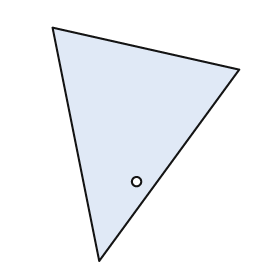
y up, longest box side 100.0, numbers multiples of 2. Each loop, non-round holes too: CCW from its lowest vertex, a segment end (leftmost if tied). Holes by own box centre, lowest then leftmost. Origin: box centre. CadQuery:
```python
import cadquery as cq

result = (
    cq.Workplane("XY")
    .moveTo(-20.0, -50.0)
    .lineTo(40.0, 32.0)
    .lineTo(-40.0, 50.0)
    .close()
    .moveTo(-4.0, -16.0)
    .circle(2.0)
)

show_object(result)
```